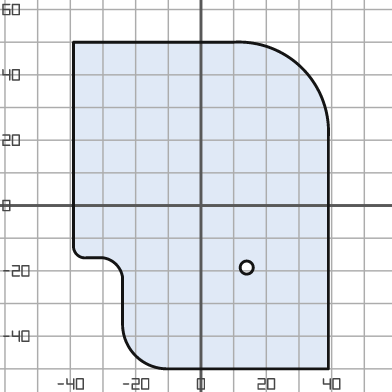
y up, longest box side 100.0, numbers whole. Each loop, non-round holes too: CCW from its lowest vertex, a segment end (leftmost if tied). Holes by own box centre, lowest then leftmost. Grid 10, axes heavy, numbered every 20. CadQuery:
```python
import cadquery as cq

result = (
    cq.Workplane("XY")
    .moveTo(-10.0, -50.0)
    .lineTo(39.0, -50.0)
    .lineTo(39.0, 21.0)
    .threePointArc((31.0, 42.0), (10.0, 50.0))
    .lineTo(-39.0, 50.0)
    .lineTo(-39.0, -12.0)
    .threePointArc((-38.0, -15.0), (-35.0, -16.0))
    .lineTo(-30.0, -16.0)
    .threePointArc((-26.0, -18.0), (-24.0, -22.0))
    .lineTo(-24.0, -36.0)
    .threePointArc((-20.0, -46.0), (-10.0, -50.0))
    .close()
    .moveTo(14.0, -19.0)
    .circle(2.0)
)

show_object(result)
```